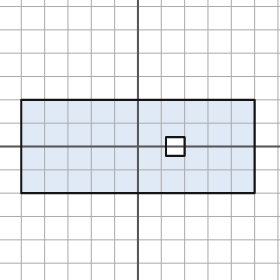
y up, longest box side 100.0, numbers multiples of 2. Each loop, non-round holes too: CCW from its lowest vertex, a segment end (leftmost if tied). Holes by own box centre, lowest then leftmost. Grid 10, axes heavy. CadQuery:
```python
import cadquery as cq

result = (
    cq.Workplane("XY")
    .moveTo(-50.0, -20.0)
    .lineTo(50.0, -20.0)
    .lineTo(50.0, 20.0)
    .lineTo(-50.0, 20.0)
    .close()
    .moveTo(12.0, -4.0)
    .lineTo(20.0, -4.0)
    .lineTo(20.0, 4.0)
    .lineTo(12.0, 4.0)
    .close()
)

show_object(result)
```